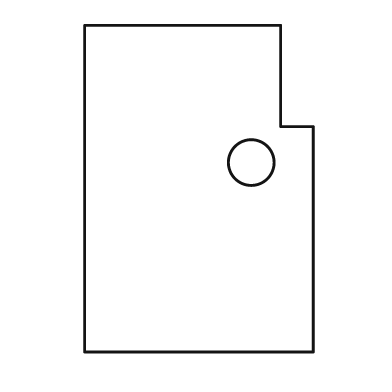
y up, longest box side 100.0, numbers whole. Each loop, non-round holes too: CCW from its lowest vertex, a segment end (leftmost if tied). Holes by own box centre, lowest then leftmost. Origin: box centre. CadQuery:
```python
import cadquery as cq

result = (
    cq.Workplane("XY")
    .moveTo(-35.0, -50.0)
    .lineTo(35.0, -50.0)
    .lineTo(35.0, 19.0)
    .lineTo(25.0, 19.0)
    .lineTo(25.0, 50.0)
    .lineTo(-35.0, 50.0)
    .close()
    .moveTo(16.0, 8.0)
    .circle(7.0)
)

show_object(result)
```